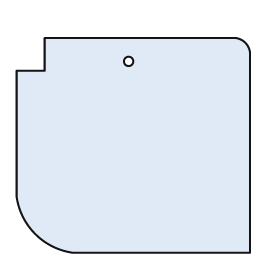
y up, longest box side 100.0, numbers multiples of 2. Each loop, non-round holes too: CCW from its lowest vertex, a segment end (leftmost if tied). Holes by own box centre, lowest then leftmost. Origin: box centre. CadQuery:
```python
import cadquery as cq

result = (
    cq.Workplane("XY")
    .moveTo(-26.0, -46.0)
    .lineTo(50.0, -46.0)
    .lineTo(50.0, 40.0)
    .threePointArc((48.0, 44.0), (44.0, 46.0))
    .lineTo(-38.0, 46.0)
    .lineTo(-38.0, 32.0)
    .lineTo(-50.0, 32.0)
    .lineTo(-50.0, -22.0)
    .threePointArc((-42.0, -38.0), (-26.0, -46.0))
    .close()
    .moveTo(-2.0, 36.0)
    .circle(2.0)
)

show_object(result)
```